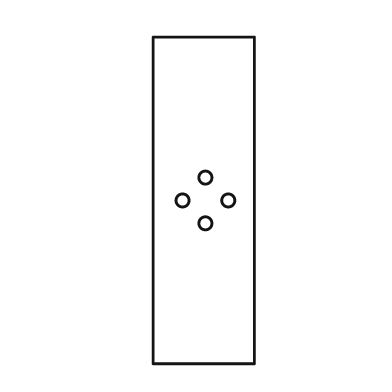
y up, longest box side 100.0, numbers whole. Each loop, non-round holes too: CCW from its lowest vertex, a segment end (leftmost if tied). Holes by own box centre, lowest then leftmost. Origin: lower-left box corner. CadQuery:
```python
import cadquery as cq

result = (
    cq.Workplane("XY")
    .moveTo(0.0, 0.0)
    .lineTo(31.0, 0.0)
    .lineTo(31.0, 100.0)
    .lineTo(0.0, 100.0)
    .close()
    .moveTo(16.0, 43.0)
    .circle(2.0)
    .moveTo(9.0, 50.0)
    .circle(2.0)
    .moveTo(23.0, 50.0)
    .circle(2.0)
    .moveTo(16.0, 57.0)
    .circle(2.0)
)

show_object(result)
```